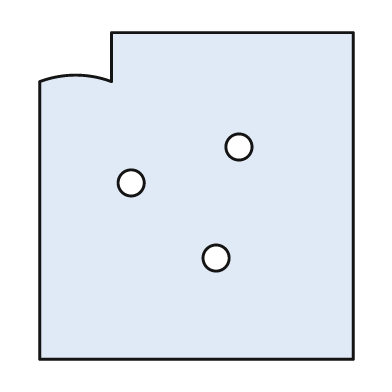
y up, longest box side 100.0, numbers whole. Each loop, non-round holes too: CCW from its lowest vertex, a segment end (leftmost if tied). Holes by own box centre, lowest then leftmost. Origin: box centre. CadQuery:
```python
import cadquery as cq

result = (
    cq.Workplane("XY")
    .moveTo(-48.0, -50.0)
    .lineTo(48.0, -50.0)
    .lineTo(48.0, 50.0)
    .lineTo(-26.0, 50.0)
    .lineTo(-26.0, 35.0)
    .threePointArc((-37.0, 37.0), (-48.0, 35.0))
    .close()
    .moveTo(6.0, -19.0)
    .circle(4.0)
    .moveTo(-20.0, 4.0)
    .circle(4.0)
    .moveTo(13.0, 15.0)
    .circle(4.0)
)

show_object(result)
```